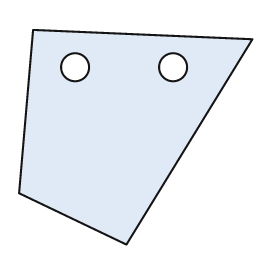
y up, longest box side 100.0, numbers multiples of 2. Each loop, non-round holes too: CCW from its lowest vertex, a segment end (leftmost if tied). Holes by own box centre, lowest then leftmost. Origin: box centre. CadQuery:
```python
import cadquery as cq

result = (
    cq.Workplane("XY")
    .moveTo(-4.0, -46.0)
    .lineTo(50.0, 42.0)
    .lineTo(-44.0, 46.0)
    .lineTo(-50.0, -24.0)
    .close()
    .moveTo(-26.0, 30.0)
    .circle(6.0)
    .moveTo(16.0, 30.0)
    .circle(6.0)
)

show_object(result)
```